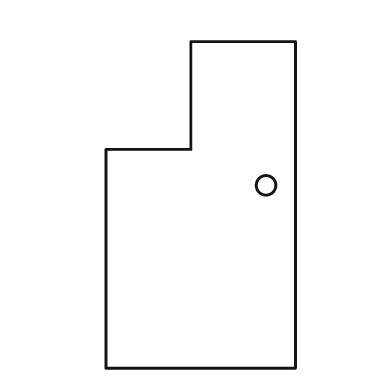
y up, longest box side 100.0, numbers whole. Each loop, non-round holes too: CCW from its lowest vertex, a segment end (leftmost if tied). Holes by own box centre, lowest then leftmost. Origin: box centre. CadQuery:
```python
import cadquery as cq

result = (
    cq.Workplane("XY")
    .moveTo(-29.0, -50.0)
    .lineTo(29.0, -50.0)
    .lineTo(29.0, 50.0)
    .lineTo(-3.0, 50.0)
    .lineTo(-3.0, 17.0)
    .lineTo(-29.0, 17.0)
    .close()
    .moveTo(20.0, 6.0)
    .circle(3.0)
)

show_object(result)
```